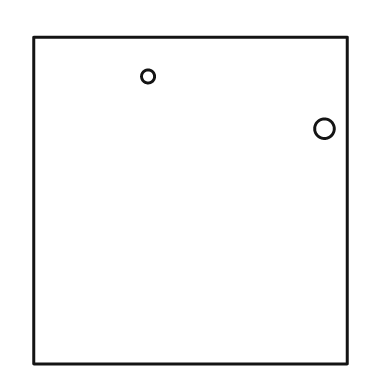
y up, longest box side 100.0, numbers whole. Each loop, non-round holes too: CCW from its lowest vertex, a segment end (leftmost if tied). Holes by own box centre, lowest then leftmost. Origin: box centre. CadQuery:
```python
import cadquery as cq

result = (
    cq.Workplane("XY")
    .moveTo(-48.0, -50.0)
    .lineTo(48.0, -50.0)
    .lineTo(48.0, 50.0)
    .lineTo(-48.0, 50.0)
    .close()
    .moveTo(41.0, 22.0)
    .circle(3.0)
    .moveTo(-13.0, 38.0)
    .circle(2.0)
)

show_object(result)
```